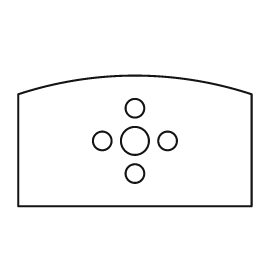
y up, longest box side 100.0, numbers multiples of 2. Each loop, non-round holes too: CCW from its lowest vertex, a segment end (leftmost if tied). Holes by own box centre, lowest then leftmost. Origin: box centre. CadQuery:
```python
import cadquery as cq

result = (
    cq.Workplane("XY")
    .moveTo(-50.0, -28.0)
    .lineTo(50.0, -28.0)
    .lineTo(50.0, 20.0)
    .threePointArc((0.0, 28.0), (-50.0, 20.0))
    .close()
    .moveTo(0.0, -14.0)
    .circle(4.0)
    .moveTo(-14.0, 0.0)
    .circle(4.0)
    .moveTo(0.0, 0.0)
    .circle(6.0)
    .moveTo(14.0, 0.0)
    .circle(4.0)
    .moveTo(0.0, 14.0)
    .circle(4.0)
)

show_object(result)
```